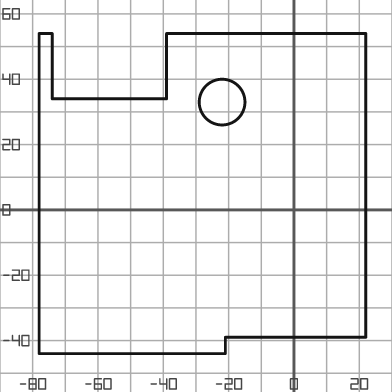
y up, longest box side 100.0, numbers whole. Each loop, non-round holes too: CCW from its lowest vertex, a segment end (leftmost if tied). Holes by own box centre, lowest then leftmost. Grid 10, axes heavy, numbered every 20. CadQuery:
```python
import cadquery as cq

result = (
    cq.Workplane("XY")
    .moveTo(-78.0, -44.0)
    .lineTo(-21.0, -44.0)
    .lineTo(-21.0, -39.0)
    .lineTo(22.0, -39.0)
    .lineTo(22.0, 54.0)
    .lineTo(-39.0, 54.0)
    .lineTo(-39.0, 34.0)
    .lineTo(-74.0, 34.0)
    .lineTo(-74.0, 54.0)
    .lineTo(-78.0, 54.0)
    .close()
    .moveTo(-22.0, 33.0)
    .circle(7.0)
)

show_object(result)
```